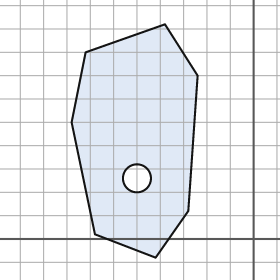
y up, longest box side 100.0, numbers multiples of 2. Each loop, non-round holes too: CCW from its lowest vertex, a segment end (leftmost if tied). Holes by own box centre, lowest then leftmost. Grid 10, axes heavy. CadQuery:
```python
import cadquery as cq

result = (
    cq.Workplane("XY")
    .moveTo(-42.0, -8.0)
    .lineTo(-28.0, 12.0)
    .lineTo(-24.0, 70.0)
    .lineTo(-38.0, 92.0)
    .lineTo(-72.0, 80.0)
    .lineTo(-78.0, 50.0)
    .lineTo(-68.0, 2.0)
    .close()
    .moveTo(-50.0, 26.0)
    .circle(6.0)
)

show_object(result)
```